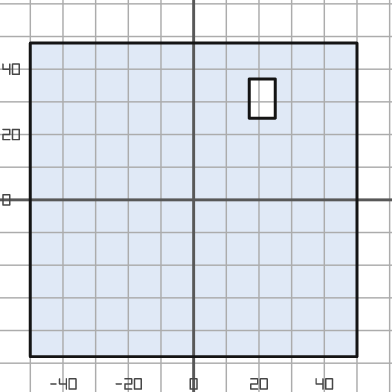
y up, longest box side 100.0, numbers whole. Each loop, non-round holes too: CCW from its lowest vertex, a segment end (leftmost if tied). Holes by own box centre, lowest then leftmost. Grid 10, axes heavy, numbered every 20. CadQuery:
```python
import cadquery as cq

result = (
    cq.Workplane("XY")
    .moveTo(-50.0, -48.0)
    .lineTo(50.0, -48.0)
    .lineTo(50.0, 48.0)
    .lineTo(-50.0, 48.0)
    .close()
    .moveTo(17.0, 25.0)
    .lineTo(25.0, 25.0)
    .lineTo(25.0, 37.0)
    .lineTo(17.0, 37.0)
    .close()
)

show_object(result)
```